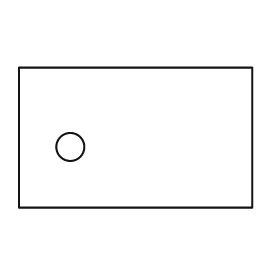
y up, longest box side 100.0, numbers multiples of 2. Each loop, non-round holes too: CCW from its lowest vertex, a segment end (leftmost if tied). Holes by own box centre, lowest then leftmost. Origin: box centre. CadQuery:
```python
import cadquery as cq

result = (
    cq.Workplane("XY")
    .moveTo(-50.0, -30.0)
    .lineTo(50.0, -30.0)
    .lineTo(50.0, 30.0)
    .lineTo(-50.0, 30.0)
    .close()
    .moveTo(-28.0, -4.0)
    .circle(6.0)
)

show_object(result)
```